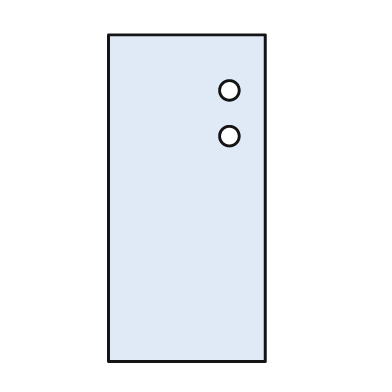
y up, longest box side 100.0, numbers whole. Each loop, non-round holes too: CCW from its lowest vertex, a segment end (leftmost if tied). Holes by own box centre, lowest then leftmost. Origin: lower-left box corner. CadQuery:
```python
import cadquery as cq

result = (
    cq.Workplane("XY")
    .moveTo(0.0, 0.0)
    .lineTo(48.0, 0.0)
    .lineTo(48.0, 100.0)
    .lineTo(0.0, 100.0)
    .close()
    .moveTo(37.0, 69.0)
    .circle(3.0)
    .moveTo(37.0, 83.0)
    .circle(3.0)
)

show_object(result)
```